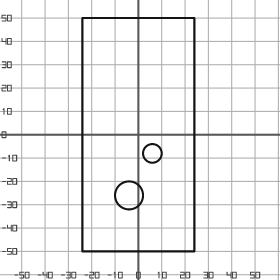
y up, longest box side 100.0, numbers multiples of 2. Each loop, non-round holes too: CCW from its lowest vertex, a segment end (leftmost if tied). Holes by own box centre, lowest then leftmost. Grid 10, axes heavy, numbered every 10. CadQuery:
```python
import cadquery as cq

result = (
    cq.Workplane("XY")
    .moveTo(-24.0, -50.0)
    .lineTo(24.0, -50.0)
    .lineTo(24.0, 50.0)
    .lineTo(-24.0, 50.0)
    .close()
    .moveTo(-4.0, -26.0)
    .circle(6.0)
    .moveTo(6.0, -8.0)
    .circle(4.0)
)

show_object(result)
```